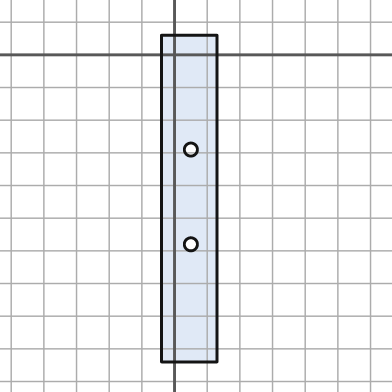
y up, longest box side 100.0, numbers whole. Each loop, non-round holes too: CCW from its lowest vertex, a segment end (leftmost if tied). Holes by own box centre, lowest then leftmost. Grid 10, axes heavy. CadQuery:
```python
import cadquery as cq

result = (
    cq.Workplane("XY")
    .moveTo(-4.0, -94.0)
    .lineTo(13.0, -94.0)
    .lineTo(13.0, 6.0)
    .lineTo(-4.0, 6.0)
    .close()
    .moveTo(5.0, -58.0)
    .circle(2.0)
    .moveTo(5.0, -29.0)
    .circle(2.0)
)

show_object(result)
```